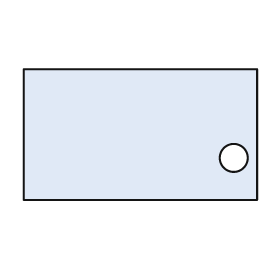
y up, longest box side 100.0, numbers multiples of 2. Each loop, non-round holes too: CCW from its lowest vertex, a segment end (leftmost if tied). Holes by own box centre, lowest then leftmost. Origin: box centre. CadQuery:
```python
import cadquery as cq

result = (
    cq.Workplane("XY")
    .moveTo(-50.0, -28.0)
    .lineTo(50.0, -28.0)
    .lineTo(50.0, 28.0)
    .lineTo(-50.0, 28.0)
    .close()
    .moveTo(40.0, -10.0)
    .circle(6.0)
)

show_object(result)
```